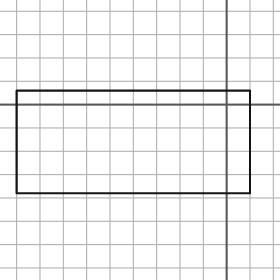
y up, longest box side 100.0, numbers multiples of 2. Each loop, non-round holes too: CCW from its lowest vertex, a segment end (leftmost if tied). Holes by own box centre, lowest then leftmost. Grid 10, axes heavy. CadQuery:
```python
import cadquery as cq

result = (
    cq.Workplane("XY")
    .moveTo(-90.0, -38.0)
    .lineTo(10.0, -38.0)
    .lineTo(10.0, 6.0)
    .lineTo(-90.0, 6.0)
    .close()
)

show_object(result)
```